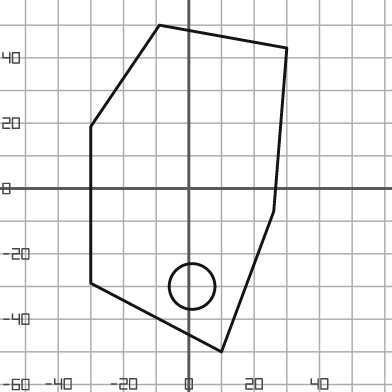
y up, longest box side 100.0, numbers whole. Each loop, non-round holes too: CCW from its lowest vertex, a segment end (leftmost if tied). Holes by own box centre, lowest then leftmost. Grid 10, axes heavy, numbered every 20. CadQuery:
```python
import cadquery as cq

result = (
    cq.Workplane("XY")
    .moveTo(10.0, -50.0)
    .lineTo(26.0, -7.0)
    .lineTo(30.0, 43.0)
    .lineTo(-9.0, 50.0)
    .lineTo(-30.0, 19.0)
    .lineTo(-30.0, -29.0)
    .close()
    .moveTo(1.0, -30.0)
    .circle(7.0)
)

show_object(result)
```